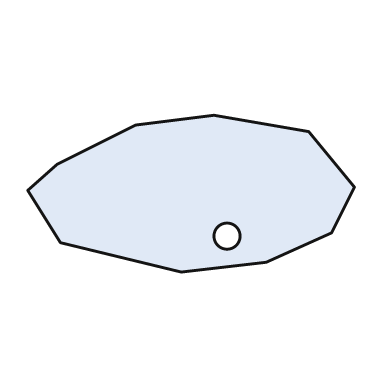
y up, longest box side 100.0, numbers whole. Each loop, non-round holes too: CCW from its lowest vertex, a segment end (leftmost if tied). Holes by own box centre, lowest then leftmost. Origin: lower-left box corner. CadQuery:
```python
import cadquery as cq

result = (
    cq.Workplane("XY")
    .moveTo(47.0, 0.0)
    .lineTo(73.0, 3.0)
    .lineTo(93.0, 12.0)
    .lineTo(100.0, 26.0)
    .lineTo(86.0, 43.0)
    .lineTo(57.0, 48.0)
    .lineTo(33.0, 45.0)
    .lineTo(9.0, 33.0)
    .lineTo(0.0, 25.0)
    .lineTo(10.0, 9.0)
    .close()
    .moveTo(61.0, 11.0)
    .circle(4.0)
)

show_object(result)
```